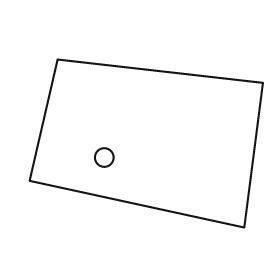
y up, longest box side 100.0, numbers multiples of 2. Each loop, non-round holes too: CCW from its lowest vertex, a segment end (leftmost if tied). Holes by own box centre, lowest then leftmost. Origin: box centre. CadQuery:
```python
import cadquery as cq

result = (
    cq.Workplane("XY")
    .moveTo(42.0, -36.0)
    .lineTo(50.0, 26.0)
    .lineTo(-38.0, 36.0)
    .lineTo(-50.0, -16.0)
    .close()
    .moveTo(-18.0, -6.0)
    .circle(4.0)
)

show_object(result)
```